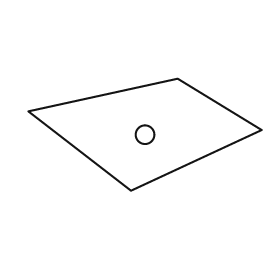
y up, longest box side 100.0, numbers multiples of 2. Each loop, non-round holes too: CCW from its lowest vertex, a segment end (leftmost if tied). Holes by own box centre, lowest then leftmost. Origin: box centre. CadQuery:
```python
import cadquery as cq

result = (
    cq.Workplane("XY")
    .moveTo(-6.0, -24.0)
    .lineTo(50.0, 2.0)
    .lineTo(14.0, 24.0)
    .lineTo(-50.0, 10.0)
    .close()
    .moveTo(0.0, 0.0)
    .circle(4.0)
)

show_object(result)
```